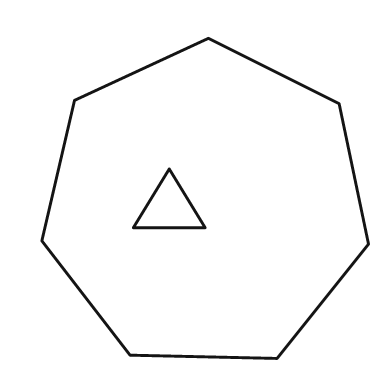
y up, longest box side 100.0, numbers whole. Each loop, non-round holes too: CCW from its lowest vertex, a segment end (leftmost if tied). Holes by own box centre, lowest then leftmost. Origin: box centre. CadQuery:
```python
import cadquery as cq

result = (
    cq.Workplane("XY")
    .moveTo(22.0, -49.0)
    .lineTo(50.0, -14.0)
    .lineTo(41.0, 29.0)
    .lineTo(1.0, 49.0)
    .lineTo(-40.0, 30.0)
    .lineTo(-50.0, -13.0)
    .lineTo(-23.0, -48.0)
    .close()
    .moveTo(-22.0, -9.0)
    .lineTo(0.0, -9.0)
    .lineTo(-11.0, 9.0)
    .close()
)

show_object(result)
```